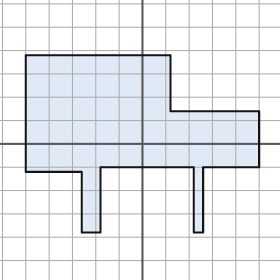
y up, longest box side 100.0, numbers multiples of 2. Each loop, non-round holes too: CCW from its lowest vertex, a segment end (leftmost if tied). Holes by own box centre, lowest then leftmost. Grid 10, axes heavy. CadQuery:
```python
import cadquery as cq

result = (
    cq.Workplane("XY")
    .moveTo(-26.0, -38.0)
    .lineTo(-18.0, -38.0)
    .lineTo(-18.0, -10.0)
    .lineTo(22.0, -10.0)
    .lineTo(22.0, -38.0)
    .lineTo(26.0, -38.0)
    .lineTo(26.0, -10.0)
    .lineTo(50.0, -10.0)
    .lineTo(50.0, 14.0)
    .lineTo(12.0, 14.0)
    .lineTo(12.0, 38.0)
    .lineTo(-50.0, 38.0)
    .lineTo(-50.0, -12.0)
    .lineTo(-26.0, -12.0)
    .close()
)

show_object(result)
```